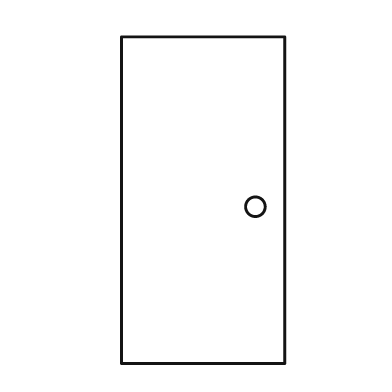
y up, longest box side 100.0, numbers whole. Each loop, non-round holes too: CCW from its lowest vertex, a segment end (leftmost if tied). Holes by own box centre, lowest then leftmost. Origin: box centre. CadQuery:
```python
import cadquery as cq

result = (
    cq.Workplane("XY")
    .moveTo(-25.0, -50.0)
    .lineTo(25.0, -50.0)
    .lineTo(25.0, 50.0)
    .lineTo(-25.0, 50.0)
    .close()
    .moveTo(16.0, -2.0)
    .circle(3.0)
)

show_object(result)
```